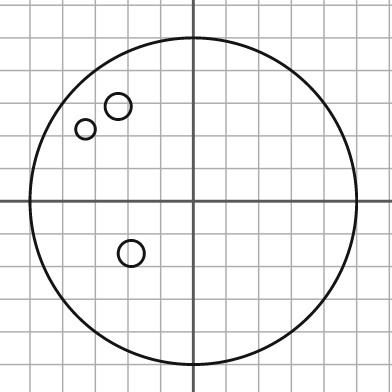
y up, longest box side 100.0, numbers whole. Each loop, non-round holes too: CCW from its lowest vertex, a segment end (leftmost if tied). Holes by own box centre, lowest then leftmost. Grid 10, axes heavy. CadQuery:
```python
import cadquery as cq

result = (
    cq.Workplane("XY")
    .moveTo(0.0, 0.0)
    .circle(50.0)
    .moveTo(-19.0, -16.0)
    .circle(4.0)
    .moveTo(-33.0, 22.0)
    .circle(3.0)
    .moveTo(-23.0, 29.0)
    .circle(4.0)
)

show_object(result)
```